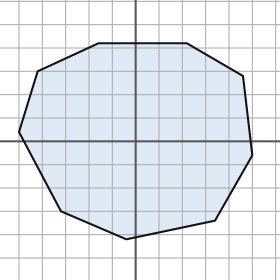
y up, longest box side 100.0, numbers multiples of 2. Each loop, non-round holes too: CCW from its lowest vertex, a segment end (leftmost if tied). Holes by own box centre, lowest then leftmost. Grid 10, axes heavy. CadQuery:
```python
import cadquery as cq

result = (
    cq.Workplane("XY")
    .moveTo(-4.0, -42.0)
    .lineTo(34.0, -34.0)
    .lineTo(50.0, -6.0)
    .lineTo(46.0, 28.0)
    .lineTo(22.0, 42.0)
    .lineTo(-16.0, 42.0)
    .lineTo(-42.0, 30.0)
    .lineTo(-50.0, 4.0)
    .lineTo(-32.0, -30.0)
    .close()
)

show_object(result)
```